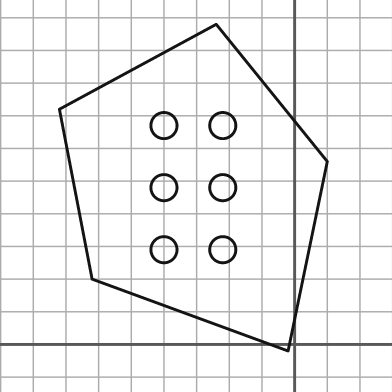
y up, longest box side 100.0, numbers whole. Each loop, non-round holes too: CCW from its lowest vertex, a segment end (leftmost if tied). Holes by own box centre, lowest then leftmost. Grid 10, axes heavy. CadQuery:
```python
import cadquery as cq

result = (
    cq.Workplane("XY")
    .moveTo(-2.0, -2.0)
    .lineTo(10.0, 56.0)
    .lineTo(-24.0, 98.0)
    .lineTo(-72.0, 72.0)
    .lineTo(-62.0, 20.0)
    .close()
    .moveTo(-40.0, 29.0)
    .circle(4.0)
    .moveTo(-22.0, 29.0)
    .circle(4.0)
    .moveTo(-40.0, 48.0)
    .circle(4.0)
    .moveTo(-22.0, 48.0)
    .circle(4.0)
    .moveTo(-40.0, 67.0)
    .circle(4.0)
    .moveTo(-22.0, 67.0)
    .circle(4.0)
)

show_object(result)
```